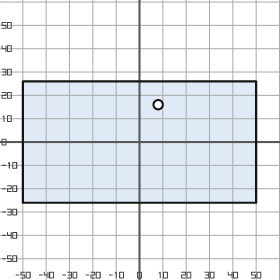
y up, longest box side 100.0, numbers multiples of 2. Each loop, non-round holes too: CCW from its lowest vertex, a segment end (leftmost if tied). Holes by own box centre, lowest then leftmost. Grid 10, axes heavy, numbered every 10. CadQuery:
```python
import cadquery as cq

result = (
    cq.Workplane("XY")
    .moveTo(-50.0, -26.0)
    .lineTo(50.0, -26.0)
    .lineTo(50.0, 26.0)
    .lineTo(-50.0, 26.0)
    .close()
    .moveTo(8.0, 16.0)
    .circle(2.0)
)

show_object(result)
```